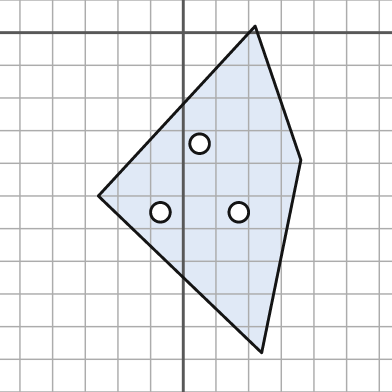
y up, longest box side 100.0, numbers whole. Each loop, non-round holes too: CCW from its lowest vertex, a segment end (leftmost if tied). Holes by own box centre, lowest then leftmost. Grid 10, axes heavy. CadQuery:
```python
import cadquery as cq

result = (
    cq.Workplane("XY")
    .moveTo(24.0, -98.0)
    .lineTo(36.0, -39.0)
    .lineTo(22.0, 2.0)
    .lineTo(-26.0, -50.0)
    .close()
    .moveTo(-7.0, -55.0)
    .circle(3.0)
    .moveTo(17.0, -55.0)
    .circle(3.0)
    .moveTo(5.0, -34.0)
    .circle(3.0)
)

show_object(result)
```